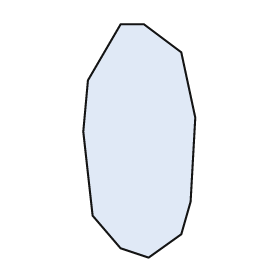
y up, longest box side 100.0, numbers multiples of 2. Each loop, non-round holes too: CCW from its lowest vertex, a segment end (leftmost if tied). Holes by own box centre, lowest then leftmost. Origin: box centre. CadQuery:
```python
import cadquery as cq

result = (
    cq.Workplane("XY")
    .moveTo(4.0, -50.0)
    .lineTo(18.0, -40.0)
    .lineTo(22.0, -26.0)
    .lineTo(24.0, 10.0)
    .lineTo(18.0, 38.0)
    .lineTo(2.0, 50.0)
    .lineTo(-8.0, 50.0)
    .lineTo(-22.0, 26.0)
    .lineTo(-24.0, 4.0)
    .lineTo(-20.0, -32.0)
    .lineTo(-8.0, -46.0)
    .close()
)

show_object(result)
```